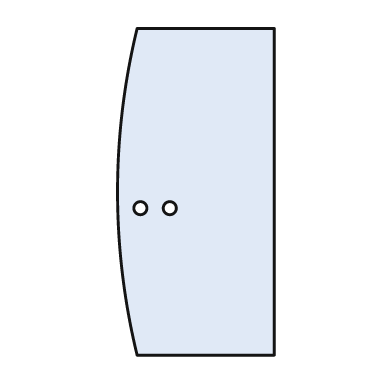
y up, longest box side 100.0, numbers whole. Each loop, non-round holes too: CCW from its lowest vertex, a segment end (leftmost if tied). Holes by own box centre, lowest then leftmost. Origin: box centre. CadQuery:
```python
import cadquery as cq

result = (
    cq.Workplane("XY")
    .moveTo(-18.0, -50.0)
    .lineTo(24.0, -50.0)
    .lineTo(24.0, 50.0)
    .lineTo(-18.0, 50.0)
    .threePointArc((-24.0, 0.0), (-18.0, -50.0))
    .close()
    .moveTo(-17.0, -5.0)
    .circle(2.0)
    .moveTo(-8.0, -5.0)
    .circle(2.0)
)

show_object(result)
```